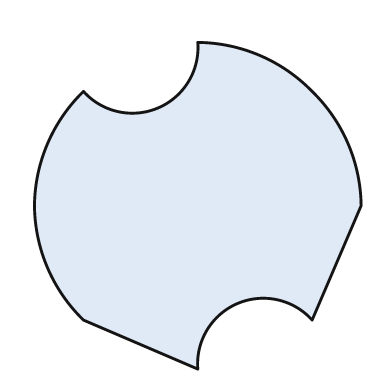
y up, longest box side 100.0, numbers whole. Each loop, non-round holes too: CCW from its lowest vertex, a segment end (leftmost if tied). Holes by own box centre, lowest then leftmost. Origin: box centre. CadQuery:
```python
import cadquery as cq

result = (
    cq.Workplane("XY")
    .moveTo(0.0, -50.0)
    .threePointArc((12.0, -30.0), (35.0, -35.0))
    .lineTo(50.0, 0.0)
    .threePointArc((46.0, 19.0), (35.0, 35.0))
    .threePointArc((19.0, 46.0), (0.0, 50.0))
    .threePointArc((-12.0, 30.0), (-35.0, 35.0))
    .threePointArc((-46.0, 19.0), (-50.0, 0.0))
    .threePointArc((-46.0, -19.0), (-35.0, -35.0))
    .close()
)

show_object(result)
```